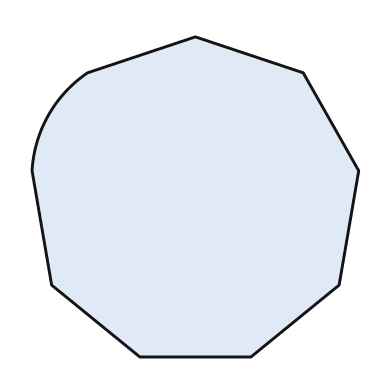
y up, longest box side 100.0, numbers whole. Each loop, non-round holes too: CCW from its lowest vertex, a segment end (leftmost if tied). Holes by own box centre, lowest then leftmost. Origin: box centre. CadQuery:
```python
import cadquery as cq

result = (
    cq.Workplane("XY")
    .moveTo(-17.0, -49.0)
    .lineTo(17.0, -49.0)
    .lineTo(44.0, -27.0)
    .lineTo(50.0, 8.0)
    .lineTo(33.0, 38.0)
    .lineTo(0.0, 49.0)
    .lineTo(-33.0, 38.0)
    .threePointArc((-45.0, 25.0), (-50.0, 8.0))
    .lineTo(-44.0, -27.0)
    .close()
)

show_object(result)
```